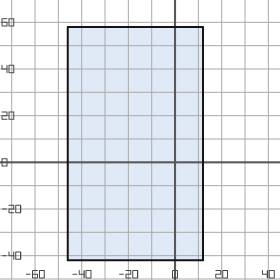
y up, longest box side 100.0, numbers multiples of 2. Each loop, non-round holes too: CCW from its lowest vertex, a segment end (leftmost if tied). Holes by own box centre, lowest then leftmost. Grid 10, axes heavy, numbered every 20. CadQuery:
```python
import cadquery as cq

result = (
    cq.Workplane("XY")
    .moveTo(-46.0, -42.0)
    .lineTo(12.0, -42.0)
    .lineTo(12.0, 58.0)
    .lineTo(-46.0, 58.0)
    .close()
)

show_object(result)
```